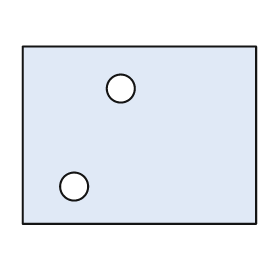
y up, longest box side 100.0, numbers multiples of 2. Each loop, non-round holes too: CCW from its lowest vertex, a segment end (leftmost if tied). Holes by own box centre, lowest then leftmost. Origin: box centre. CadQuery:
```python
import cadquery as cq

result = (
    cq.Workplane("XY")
    .moveTo(-50.0, -38.0)
    .lineTo(50.0, -38.0)
    .lineTo(50.0, 38.0)
    .lineTo(-50.0, 38.0)
    .close()
    .moveTo(-28.0, -22.0)
    .circle(6.0)
    .moveTo(-8.0, 20.0)
    .circle(6.0)
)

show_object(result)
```